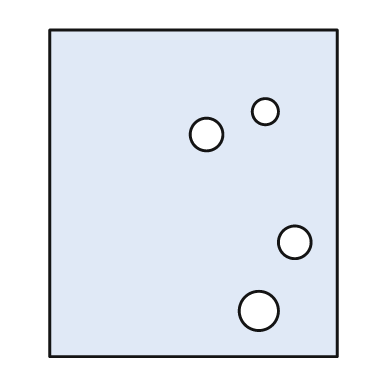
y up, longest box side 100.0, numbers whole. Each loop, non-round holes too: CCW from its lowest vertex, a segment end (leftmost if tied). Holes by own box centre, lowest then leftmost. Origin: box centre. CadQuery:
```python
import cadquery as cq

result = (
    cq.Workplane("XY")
    .moveTo(-44.0, -50.0)
    .lineTo(44.0, -50.0)
    .lineTo(44.0, 50.0)
    .lineTo(-44.0, 50.0)
    .close()
    .moveTo(20.0, -36.0)
    .circle(6.0)
    .moveTo(31.0, -15.0)
    .circle(5.0)
    .moveTo(4.0, 18.0)
    .circle(5.0)
    .moveTo(22.0, 25.0)
    .circle(4.0)
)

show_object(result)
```